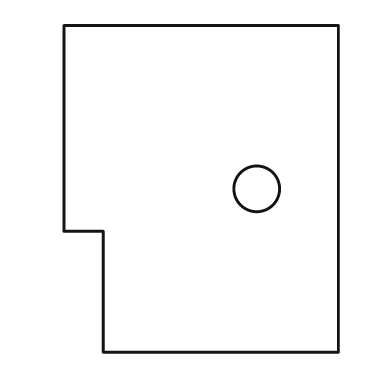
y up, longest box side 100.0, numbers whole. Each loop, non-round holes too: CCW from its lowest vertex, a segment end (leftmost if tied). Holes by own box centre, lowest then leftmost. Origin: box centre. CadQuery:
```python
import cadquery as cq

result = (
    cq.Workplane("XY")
    .moveTo(-30.0, -50.0)
    .lineTo(42.0, -50.0)
    .lineTo(42.0, 50.0)
    .lineTo(-42.0, 50.0)
    .lineTo(-42.0, -13.0)
    .lineTo(-30.0, -13.0)
    .close()
    .moveTo(17.0, 0.0)
    .circle(7.0)
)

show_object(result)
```